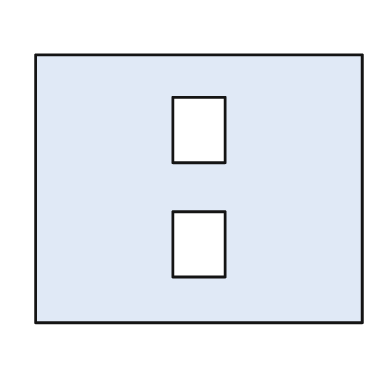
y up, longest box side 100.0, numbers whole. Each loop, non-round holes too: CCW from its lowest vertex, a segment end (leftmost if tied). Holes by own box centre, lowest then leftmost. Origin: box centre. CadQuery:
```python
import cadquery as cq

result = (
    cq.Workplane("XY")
    .moveTo(-50.0, -41.0)
    .lineTo(50.0, -41.0)
    .lineTo(50.0, 41.0)
    .lineTo(-50.0, 41.0)
    .close()
    .moveTo(-8.0, -27.0)
    .lineTo(8.0, -27.0)
    .lineTo(8.0, -7.0)
    .lineTo(-8.0, -7.0)
    .close()
    .moveTo(-8.0, 8.0)
    .lineTo(8.0, 8.0)
    .lineTo(8.0, 28.0)
    .lineTo(-8.0, 28.0)
    .close()
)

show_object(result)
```